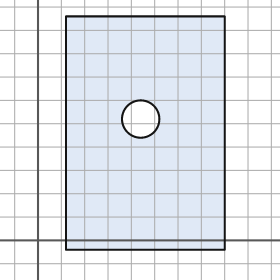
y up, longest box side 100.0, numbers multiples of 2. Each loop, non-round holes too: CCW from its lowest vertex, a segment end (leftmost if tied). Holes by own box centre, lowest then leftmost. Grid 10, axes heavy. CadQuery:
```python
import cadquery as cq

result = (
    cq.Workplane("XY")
    .moveTo(12.0, -4.0)
    .lineTo(80.0, -4.0)
    .lineTo(80.0, 96.0)
    .lineTo(12.0, 96.0)
    .close()
    .moveTo(44.0, 52.0)
    .circle(8.0)
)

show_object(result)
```